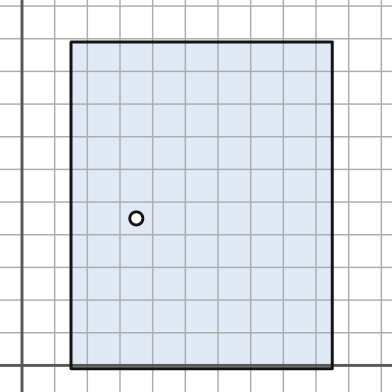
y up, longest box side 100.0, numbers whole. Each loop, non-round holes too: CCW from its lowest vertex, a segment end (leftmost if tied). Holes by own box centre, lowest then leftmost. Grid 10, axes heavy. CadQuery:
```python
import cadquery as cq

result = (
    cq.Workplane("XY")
    .moveTo(15.0, -1.0)
    .lineTo(95.0, -1.0)
    .lineTo(95.0, 99.0)
    .lineTo(15.0, 99.0)
    .close()
    .moveTo(35.0, 45.0)
    .circle(2.0)
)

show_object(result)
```